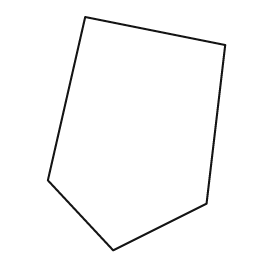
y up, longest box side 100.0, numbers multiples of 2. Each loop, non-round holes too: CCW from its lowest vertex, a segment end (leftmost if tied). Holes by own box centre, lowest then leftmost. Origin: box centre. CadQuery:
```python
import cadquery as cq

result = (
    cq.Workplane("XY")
    .moveTo(-10.0, -50.0)
    .lineTo(30.0, -30.0)
    .lineTo(38.0, 38.0)
    .lineTo(-22.0, 50.0)
    .lineTo(-38.0, -20.0)
    .close()
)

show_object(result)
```